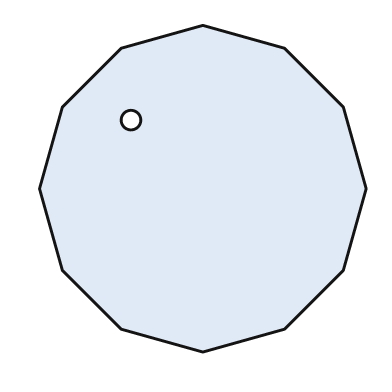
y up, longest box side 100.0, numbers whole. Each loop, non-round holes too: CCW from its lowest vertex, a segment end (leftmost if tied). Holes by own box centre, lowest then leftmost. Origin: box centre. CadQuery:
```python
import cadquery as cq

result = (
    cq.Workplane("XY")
    .moveTo(0.0, -50.0)
    .lineTo(25.0, -43.0)
    .lineTo(43.0, -25.0)
    .lineTo(50.0, 0.0)
    .lineTo(43.0, 25.0)
    .lineTo(25.0, 43.0)
    .lineTo(0.0, 50.0)
    .lineTo(-25.0, 43.0)
    .lineTo(-43.0, 25.0)
    .lineTo(-50.0, 0.0)
    .lineTo(-43.0, -25.0)
    .lineTo(-25.0, -43.0)
    .close()
    .moveTo(-22.0, 21.0)
    .circle(3.0)
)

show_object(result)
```